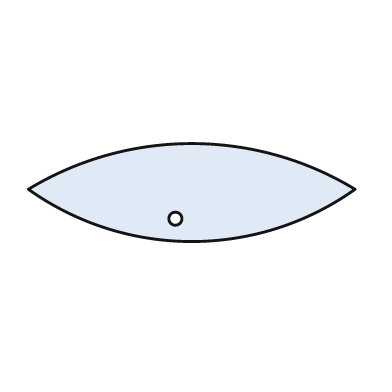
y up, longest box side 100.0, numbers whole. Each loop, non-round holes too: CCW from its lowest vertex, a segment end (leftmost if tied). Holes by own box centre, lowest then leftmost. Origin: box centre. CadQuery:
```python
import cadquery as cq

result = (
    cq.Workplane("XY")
    .moveTo(-50.0, 1.0)
    .threePointArc((0.0, -15.0), (50.0, 1.0))
    .threePointArc((0.0, 15.0), (-50.0, 1.0))
    .close()
    .moveTo(-5.0, -8.0)
    .circle(2.0)
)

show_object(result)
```